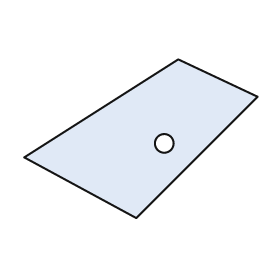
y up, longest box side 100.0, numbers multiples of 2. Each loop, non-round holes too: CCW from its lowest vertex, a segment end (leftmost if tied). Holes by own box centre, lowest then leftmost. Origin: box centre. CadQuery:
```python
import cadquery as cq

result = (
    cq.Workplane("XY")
    .moveTo(-2.0, -34.0)
    .lineTo(50.0, 18.0)
    .lineTo(16.0, 34.0)
    .lineTo(-50.0, -8.0)
    .close()
    .moveTo(10.0, -2.0)
    .circle(4.0)
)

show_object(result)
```